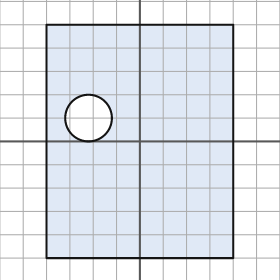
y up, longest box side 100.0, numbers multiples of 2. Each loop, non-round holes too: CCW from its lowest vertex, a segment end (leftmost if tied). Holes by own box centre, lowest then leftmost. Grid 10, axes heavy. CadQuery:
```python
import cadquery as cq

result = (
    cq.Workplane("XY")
    .moveTo(-40.0, -50.0)
    .lineTo(40.0, -50.0)
    .lineTo(40.0, 50.0)
    .lineTo(-40.0, 50.0)
    .close()
    .moveTo(-22.0, 10.0)
    .circle(10.0)
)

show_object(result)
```